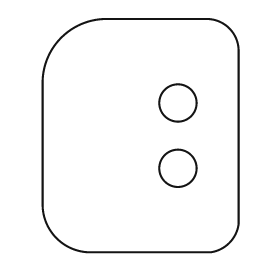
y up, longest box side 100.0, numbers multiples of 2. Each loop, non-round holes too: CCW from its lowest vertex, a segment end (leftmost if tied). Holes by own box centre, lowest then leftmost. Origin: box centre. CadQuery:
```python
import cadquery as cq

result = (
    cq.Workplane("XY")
    .moveTo(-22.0, -50.0)
    .lineTo(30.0, -50.0)
    .threePointArc((38.0, -46.0), (42.0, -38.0))
    .lineTo(42.0, 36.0)
    .threePointArc((38.0, 46.0), (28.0, 50.0))
    .lineTo(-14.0, 50.0)
    .threePointArc((-34.0, 42.0), (-42.0, 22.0))
    .lineTo(-42.0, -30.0)
    .threePointArc((-36.0, -44.0), (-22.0, -50.0))
    .close()
    .moveTo(16.0, -14.0)
    .circle(8.0)
    .moveTo(16.0, 14.0)
    .circle(8.0)
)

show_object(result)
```